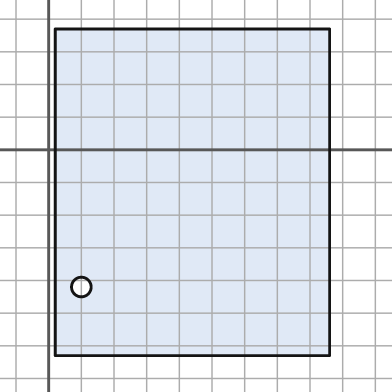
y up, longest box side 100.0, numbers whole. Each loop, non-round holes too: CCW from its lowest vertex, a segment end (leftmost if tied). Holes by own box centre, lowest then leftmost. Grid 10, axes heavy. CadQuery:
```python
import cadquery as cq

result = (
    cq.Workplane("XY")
    .moveTo(2.0, -63.0)
    .lineTo(86.0, -63.0)
    .lineTo(86.0, 37.0)
    .lineTo(2.0, 37.0)
    .close()
    .moveTo(10.0, -42.0)
    .circle(3.0)
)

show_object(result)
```